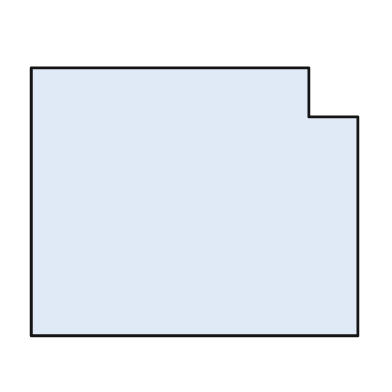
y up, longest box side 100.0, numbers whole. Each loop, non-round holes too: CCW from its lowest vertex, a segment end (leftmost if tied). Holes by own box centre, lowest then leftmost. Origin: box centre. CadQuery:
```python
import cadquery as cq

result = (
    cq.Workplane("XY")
    .moveTo(-50.0, -41.0)
    .lineTo(50.0, -41.0)
    .lineTo(50.0, 26.0)
    .lineTo(35.0, 26.0)
    .lineTo(35.0, 41.0)
    .lineTo(-50.0, 41.0)
    .close()
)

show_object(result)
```